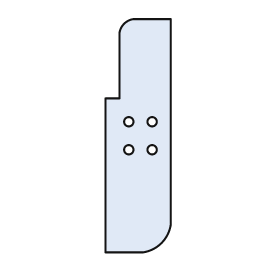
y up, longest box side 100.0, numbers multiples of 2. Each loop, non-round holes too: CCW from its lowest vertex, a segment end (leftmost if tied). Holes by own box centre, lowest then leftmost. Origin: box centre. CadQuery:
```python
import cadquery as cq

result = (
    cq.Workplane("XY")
    .moveTo(-14.0, -50.0)
    .lineTo(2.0, -50.0)
    .threePointArc((10.0, -46.0), (14.0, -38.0))
    .lineTo(14.0, 50.0)
    .lineTo(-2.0, 50.0)
    .threePointArc((-6.0, 48.0), (-8.0, 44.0))
    .lineTo(-8.0, 16.0)
    .lineTo(-14.0, 16.0)
    .close()
    .moveTo(-4.0, -6.0)
    .circle(2.0)
    .moveTo(6.0, -6.0)
    .circle(2.0)
    .moveTo(-4.0, 6.0)
    .circle(2.0)
    .moveTo(6.0, 6.0)
    .circle(2.0)
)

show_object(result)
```